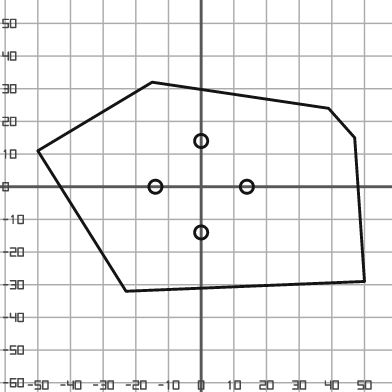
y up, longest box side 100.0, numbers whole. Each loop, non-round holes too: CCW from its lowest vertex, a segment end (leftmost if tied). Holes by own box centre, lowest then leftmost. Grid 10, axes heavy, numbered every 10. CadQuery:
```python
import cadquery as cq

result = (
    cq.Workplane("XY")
    .moveTo(-23.0, -32.0)
    .lineTo(50.0, -29.0)
    .lineTo(47.0, 15.0)
    .lineTo(39.0, 24.0)
    .lineTo(-15.0, 32.0)
    .lineTo(-50.0, 11.0)
    .close()
    .moveTo(0.0, -14.0)
    .circle(2.0)
    .moveTo(-14.0, 0.0)
    .circle(2.0)
    .moveTo(14.0, 0.0)
    .circle(2.0)
    .moveTo(0.0, 14.0)
    .circle(2.0)
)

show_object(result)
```